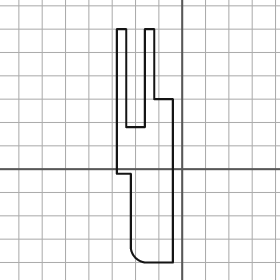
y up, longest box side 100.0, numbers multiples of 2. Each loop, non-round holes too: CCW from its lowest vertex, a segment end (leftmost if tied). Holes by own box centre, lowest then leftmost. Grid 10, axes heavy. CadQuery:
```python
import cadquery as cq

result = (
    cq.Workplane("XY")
    .moveTo(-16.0, -40.0)
    .lineTo(-4.0, -40.0)
    .lineTo(-4.0, 30.0)
    .lineTo(-12.0, 30.0)
    .lineTo(-12.0, 60.0)
    .lineTo(-16.0, 60.0)
    .lineTo(-16.0, 18.0)
    .lineTo(-24.0, 18.0)
    .lineTo(-24.0, 60.0)
    .lineTo(-28.0, 60.0)
    .lineTo(-28.0, -2.0)
    .lineTo(-22.0, -2.0)
    .lineTo(-22.0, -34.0)
    .threePointArc((-20.0, -38.0), (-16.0, -40.0))
    .close()
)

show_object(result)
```